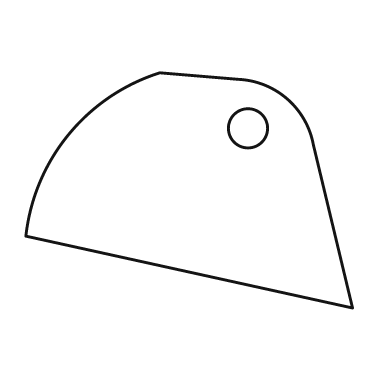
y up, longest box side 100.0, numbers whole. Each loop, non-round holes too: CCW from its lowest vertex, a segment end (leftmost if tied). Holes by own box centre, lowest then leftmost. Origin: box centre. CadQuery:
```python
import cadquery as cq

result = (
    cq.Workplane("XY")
    .moveTo(50.0, -36.0)
    .lineTo(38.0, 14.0)
    .threePointArc((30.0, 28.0), (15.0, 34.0))
    .lineTo(-9.0, 36.0)
    .threePointArc((-37.0, 17.0), (-50.0, -14.0))
    .close()
    .moveTo(18.0, 19.0)
    .circle(6.0)
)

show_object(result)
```